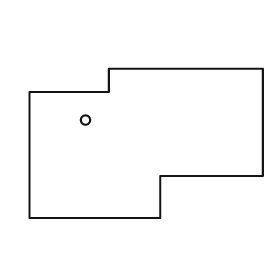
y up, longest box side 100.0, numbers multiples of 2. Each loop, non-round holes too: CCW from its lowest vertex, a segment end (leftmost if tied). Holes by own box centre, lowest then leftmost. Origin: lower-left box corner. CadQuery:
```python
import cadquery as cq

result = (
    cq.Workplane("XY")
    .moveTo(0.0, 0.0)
    .lineTo(56.0, 0.0)
    .lineTo(56.0, 18.0)
    .lineTo(100.0, 18.0)
    .lineTo(100.0, 64.0)
    .lineTo(34.0, 64.0)
    .lineTo(34.0, 54.0)
    .lineTo(0.0, 54.0)
    .close()
    .moveTo(24.0, 42.0)
    .circle(2.0)
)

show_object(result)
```